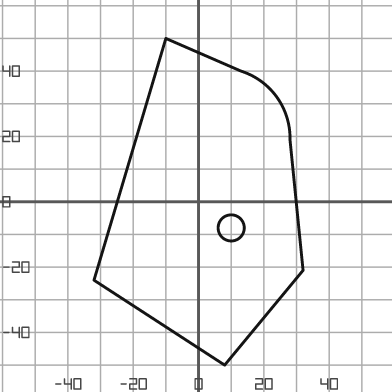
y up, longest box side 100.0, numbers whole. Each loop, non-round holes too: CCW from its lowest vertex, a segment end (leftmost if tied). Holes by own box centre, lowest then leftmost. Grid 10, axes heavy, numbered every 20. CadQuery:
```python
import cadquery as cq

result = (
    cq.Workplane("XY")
    .moveTo(8.0, -50.0)
    .lineTo(32.0, -21.0)
    .lineTo(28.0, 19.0)
    .threePointArc((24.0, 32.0), (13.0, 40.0))
    .lineTo(-10.0, 50.0)
    .lineTo(-32.0, -24.0)
    .close()
    .moveTo(10.0, -8.0)
    .circle(4.0)
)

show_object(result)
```